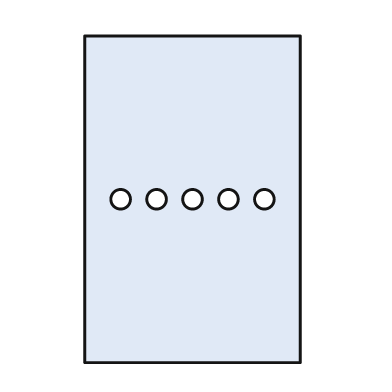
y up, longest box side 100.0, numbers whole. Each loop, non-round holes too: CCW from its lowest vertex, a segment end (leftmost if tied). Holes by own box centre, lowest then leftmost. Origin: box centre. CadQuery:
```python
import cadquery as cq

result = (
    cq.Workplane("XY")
    .moveTo(-33.0, -50.0)
    .lineTo(33.0, -50.0)
    .lineTo(33.0, 50.0)
    .lineTo(-33.0, 50.0)
    .close()
    .moveTo(-22.0, 0.0)
    .circle(3.0)
    .moveTo(-11.0, 0.0)
    .circle(3.0)
    .moveTo(0.0, 0.0)
    .circle(3.0)
    .moveTo(11.0, 0.0)
    .circle(3.0)
    .moveTo(22.0, 0.0)
    .circle(3.0)
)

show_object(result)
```